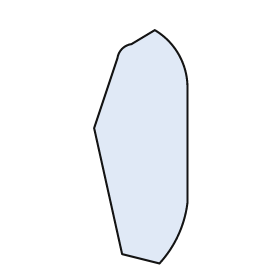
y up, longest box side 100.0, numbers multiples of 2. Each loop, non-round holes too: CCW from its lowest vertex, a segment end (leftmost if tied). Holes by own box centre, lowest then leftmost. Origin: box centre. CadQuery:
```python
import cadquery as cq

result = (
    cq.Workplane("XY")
    .moveTo(8.0, -50.0)
    .threePointArc((16.0, -38.0), (20.0, -24.0))
    .lineTo(20.0, 26.0)
    .threePointArc((16.0, 40.0), (6.0, 50.0))
    .lineTo(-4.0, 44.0)
    .threePointArc((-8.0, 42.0), (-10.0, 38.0))
    .lineTo(-20.0, 8.0)
    .lineTo(-8.0, -46.0)
    .close()
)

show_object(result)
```